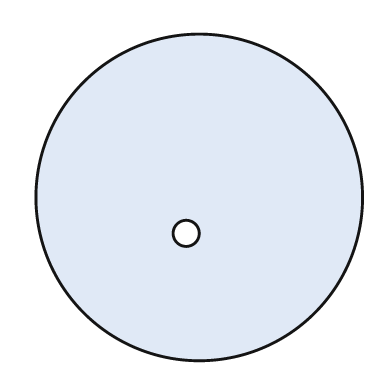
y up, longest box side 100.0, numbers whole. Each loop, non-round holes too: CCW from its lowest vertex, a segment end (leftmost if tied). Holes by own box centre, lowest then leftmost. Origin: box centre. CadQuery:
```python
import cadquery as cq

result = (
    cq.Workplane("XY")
    .moveTo(0.0, 0.0)
    .circle(50.0)
    .moveTo(-4.0, -11.0)
    .circle(4.0)
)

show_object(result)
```